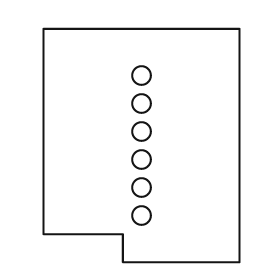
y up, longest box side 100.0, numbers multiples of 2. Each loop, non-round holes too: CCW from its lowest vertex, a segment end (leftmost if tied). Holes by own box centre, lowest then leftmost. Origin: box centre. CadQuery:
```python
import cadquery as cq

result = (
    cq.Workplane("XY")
    .moveTo(-8.0, -50.0)
    .lineTo(42.0, -50.0)
    .lineTo(42.0, 50.0)
    .lineTo(-42.0, 50.0)
    .lineTo(-42.0, -38.0)
    .lineTo(-8.0, -38.0)
    .close()
    .moveTo(0.0, -30.0)
    .circle(4.0)
    .moveTo(0.0, -18.0)
    .circle(4.0)
    .moveTo(0.0, -6.0)
    .circle(4.0)
    .moveTo(0.0, 6.0)
    .circle(4.0)
    .moveTo(0.0, 18.0)
    .circle(4.0)
    .moveTo(0.0, 30.0)
    .circle(4.0)
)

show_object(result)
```